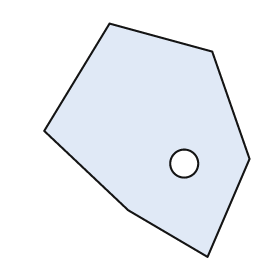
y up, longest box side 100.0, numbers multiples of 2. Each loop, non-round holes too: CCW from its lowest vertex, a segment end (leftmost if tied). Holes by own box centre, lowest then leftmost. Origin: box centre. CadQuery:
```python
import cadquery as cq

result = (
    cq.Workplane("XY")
    .moveTo(26.0, -50.0)
    .lineTo(44.0, -8.0)
    .lineTo(28.0, 38.0)
    .lineTo(-16.0, 50.0)
    .lineTo(-44.0, 4.0)
    .lineTo(-8.0, -30.0)
    .close()
    .moveTo(16.0, -10.0)
    .circle(6.0)
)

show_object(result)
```